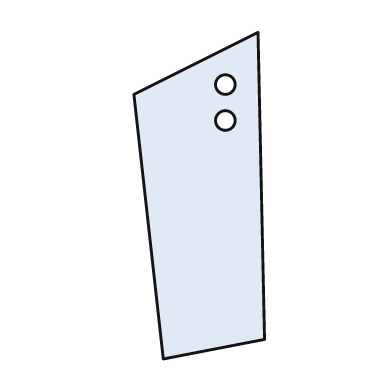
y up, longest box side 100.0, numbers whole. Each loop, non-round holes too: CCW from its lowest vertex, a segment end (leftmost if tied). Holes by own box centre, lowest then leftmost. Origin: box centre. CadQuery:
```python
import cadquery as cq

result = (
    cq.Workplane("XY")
    .moveTo(-11.0, -50.0)
    .lineTo(20.0, -44.0)
    .lineTo(18.0, 50.0)
    .lineTo(-20.0, 31.0)
    .close()
    .moveTo(8.0, 23.0)
    .circle(3.0)
    .moveTo(8.0, 34.0)
    .circle(3.0)
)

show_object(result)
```